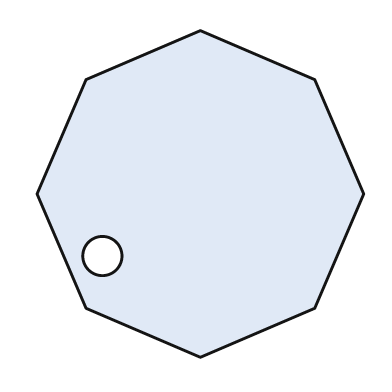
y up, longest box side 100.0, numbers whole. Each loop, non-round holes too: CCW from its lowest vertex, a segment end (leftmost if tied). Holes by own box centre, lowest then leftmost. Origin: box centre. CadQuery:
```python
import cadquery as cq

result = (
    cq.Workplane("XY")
    .moveTo(0.0, -50.0)
    .lineTo(35.0, -35.0)
    .lineTo(50.0, 0.0)
    .lineTo(35.0, 35.0)
    .lineTo(0.0, 50.0)
    .lineTo(-35.0, 35.0)
    .lineTo(-50.0, 0.0)
    .lineTo(-35.0, -35.0)
    .close()
    .moveTo(-30.0, -19.0)
    .circle(6.0)
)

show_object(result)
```